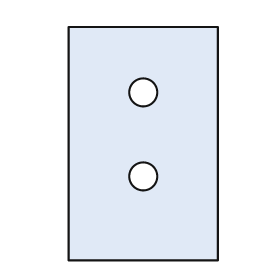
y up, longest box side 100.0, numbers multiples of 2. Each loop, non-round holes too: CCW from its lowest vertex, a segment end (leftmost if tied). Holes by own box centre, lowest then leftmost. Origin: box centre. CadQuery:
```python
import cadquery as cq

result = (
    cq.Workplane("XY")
    .moveTo(-32.0, -50.0)
    .lineTo(32.0, -50.0)
    .lineTo(32.0, 50.0)
    .lineTo(-32.0, 50.0)
    .close()
    .moveTo(0.0, -14.0)
    .circle(6.0)
    .moveTo(0.0, 22.0)
    .circle(6.0)
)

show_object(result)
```